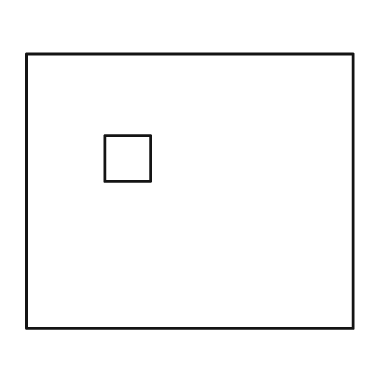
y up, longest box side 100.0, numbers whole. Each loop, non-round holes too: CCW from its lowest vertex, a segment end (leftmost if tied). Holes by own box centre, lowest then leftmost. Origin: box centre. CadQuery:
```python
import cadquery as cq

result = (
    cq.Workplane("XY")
    .moveTo(-50.0, -42.0)
    .lineTo(50.0, -42.0)
    .lineTo(50.0, 42.0)
    .lineTo(-50.0, 42.0)
    .close()
    .moveTo(-26.0, 3.0)
    .lineTo(-12.0, 3.0)
    .lineTo(-12.0, 17.0)
    .lineTo(-26.0, 17.0)
    .close()
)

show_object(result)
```